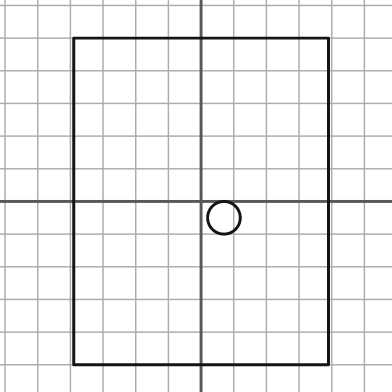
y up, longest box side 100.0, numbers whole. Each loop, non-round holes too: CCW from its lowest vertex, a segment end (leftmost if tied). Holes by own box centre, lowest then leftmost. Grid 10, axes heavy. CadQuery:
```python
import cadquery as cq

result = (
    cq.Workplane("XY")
    .moveTo(-39.0, -50.0)
    .lineTo(39.0, -50.0)
    .lineTo(39.0, 50.0)
    .lineTo(-39.0, 50.0)
    .close()
    .moveTo(7.0, -5.0)
    .circle(5.0)
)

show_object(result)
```